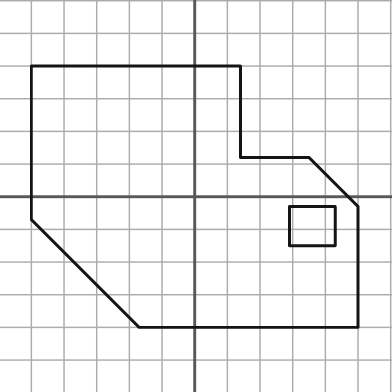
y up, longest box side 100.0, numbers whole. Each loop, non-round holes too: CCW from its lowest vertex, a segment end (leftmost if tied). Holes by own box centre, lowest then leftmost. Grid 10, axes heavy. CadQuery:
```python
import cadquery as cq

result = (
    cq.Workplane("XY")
    .moveTo(-17.0, -40.0)
    .lineTo(50.0, -40.0)
    .lineTo(50.0, -3.0)
    .lineTo(35.0, 12.0)
    .lineTo(14.0, 12.0)
    .lineTo(14.0, 40.0)
    .lineTo(-50.0, 40.0)
    .lineTo(-50.0, -7.0)
    .close()
    .moveTo(29.0, -15.0)
    .lineTo(43.0, -15.0)
    .lineTo(43.0, -3.0)
    .lineTo(29.0, -3.0)
    .close()
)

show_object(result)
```